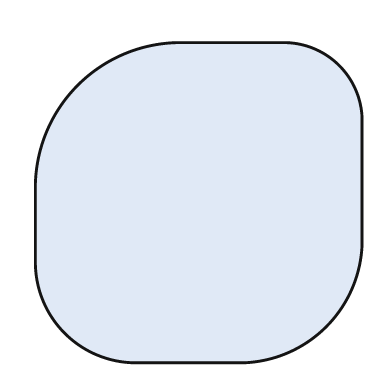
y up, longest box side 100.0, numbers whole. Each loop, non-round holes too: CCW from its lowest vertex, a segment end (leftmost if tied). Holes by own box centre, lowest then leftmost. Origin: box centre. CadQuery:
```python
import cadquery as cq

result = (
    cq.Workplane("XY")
    .moveTo(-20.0, -49.0)
    .lineTo(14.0, -49.0)
    .threePointArc((39.0, -38.0), (50.0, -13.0))
    .lineTo(50.0, 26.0)
    .threePointArc((43.0, 42.0), (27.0, 49.0))
    .lineTo(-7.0, 49.0)
    .threePointArc((-37.0, 36.0), (-50.0, 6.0))
    .lineTo(-50.0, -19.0)
    .threePointArc((-41.0, -40.0), (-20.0, -49.0))
    .close()
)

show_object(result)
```